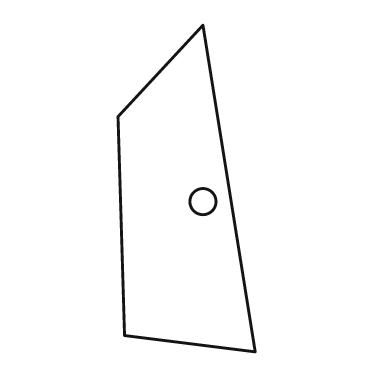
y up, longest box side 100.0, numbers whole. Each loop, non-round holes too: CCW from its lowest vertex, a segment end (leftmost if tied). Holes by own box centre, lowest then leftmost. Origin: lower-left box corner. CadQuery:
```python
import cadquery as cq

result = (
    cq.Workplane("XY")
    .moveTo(42.0, 0.0)
    .lineTo(26.0, 100.0)
    .lineTo(0.0, 72.0)
    .lineTo(2.0, 5.0)
    .close()
    .moveTo(26.0, 46.0)
    .circle(4.0)
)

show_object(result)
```